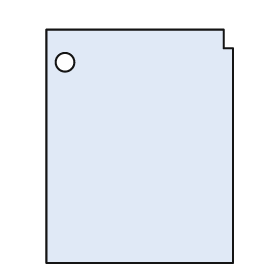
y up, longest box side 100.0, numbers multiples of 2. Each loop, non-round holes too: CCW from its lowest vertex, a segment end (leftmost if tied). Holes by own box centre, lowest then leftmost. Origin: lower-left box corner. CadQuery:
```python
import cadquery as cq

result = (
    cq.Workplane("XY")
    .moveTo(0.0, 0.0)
    .lineTo(80.0, 0.0)
    .lineTo(80.0, 92.0)
    .lineTo(76.0, 92.0)
    .lineTo(76.0, 100.0)
    .lineTo(0.0, 100.0)
    .close()
    .moveTo(8.0, 86.0)
    .circle(4.0)
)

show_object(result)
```